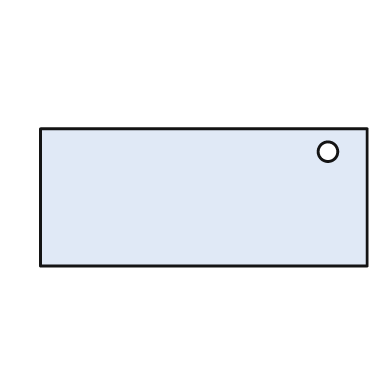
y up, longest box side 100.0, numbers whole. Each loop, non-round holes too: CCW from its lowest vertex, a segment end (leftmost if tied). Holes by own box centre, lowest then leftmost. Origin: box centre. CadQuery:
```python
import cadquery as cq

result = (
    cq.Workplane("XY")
    .moveTo(-50.0, -21.0)
    .lineTo(50.0, -21.0)
    .lineTo(50.0, 21.0)
    .lineTo(-50.0, 21.0)
    .close()
    .moveTo(38.0, 14.0)
    .circle(3.0)
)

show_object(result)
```